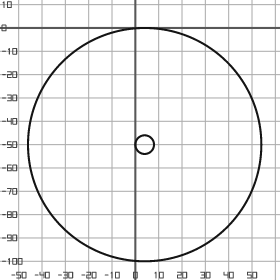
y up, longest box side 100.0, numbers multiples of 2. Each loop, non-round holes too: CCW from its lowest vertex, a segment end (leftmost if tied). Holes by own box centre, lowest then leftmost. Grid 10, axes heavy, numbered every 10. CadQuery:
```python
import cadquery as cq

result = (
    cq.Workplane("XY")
    .moveTo(4.0, -50.0)
    .circle(50.0)
    .moveTo(4.0, -50.0)
    .circle(4.0)
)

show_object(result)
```